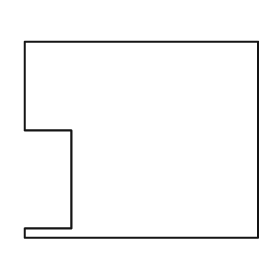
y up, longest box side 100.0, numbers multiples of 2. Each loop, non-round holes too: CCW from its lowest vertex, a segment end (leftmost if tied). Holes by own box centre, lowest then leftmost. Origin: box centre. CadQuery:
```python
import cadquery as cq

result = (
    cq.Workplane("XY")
    .moveTo(-50.0, -42.0)
    .lineTo(50.0, -42.0)
    .lineTo(50.0, 42.0)
    .lineTo(-50.0, 42.0)
    .lineTo(-50.0, 4.0)
    .lineTo(-30.0, 4.0)
    .lineTo(-30.0, -38.0)
    .lineTo(-50.0, -38.0)
    .close()
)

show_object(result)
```